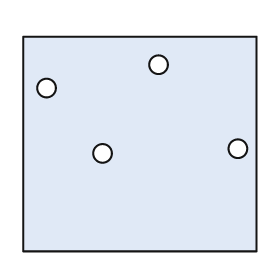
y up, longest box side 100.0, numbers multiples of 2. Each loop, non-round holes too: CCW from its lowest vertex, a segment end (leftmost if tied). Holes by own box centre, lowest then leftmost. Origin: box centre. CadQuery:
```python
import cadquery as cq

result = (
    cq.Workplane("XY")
    .moveTo(-50.0, -46.0)
    .lineTo(50.0, -46.0)
    .lineTo(50.0, 46.0)
    .lineTo(-50.0, 46.0)
    .close()
    .moveTo(-16.0, -4.0)
    .circle(4.0)
    .moveTo(42.0, -2.0)
    .circle(4.0)
    .moveTo(-40.0, 24.0)
    .circle(4.0)
    .moveTo(8.0, 34.0)
    .circle(4.0)
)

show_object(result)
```